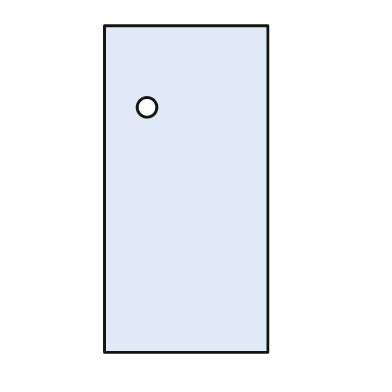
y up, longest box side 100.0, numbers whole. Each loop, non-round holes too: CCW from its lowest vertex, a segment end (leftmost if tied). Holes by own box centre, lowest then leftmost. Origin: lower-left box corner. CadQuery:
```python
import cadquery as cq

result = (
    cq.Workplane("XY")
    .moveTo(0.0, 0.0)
    .lineTo(50.0, 0.0)
    .lineTo(50.0, 100.0)
    .lineTo(0.0, 100.0)
    .close()
    .moveTo(13.0, 75.0)
    .circle(3.0)
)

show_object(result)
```